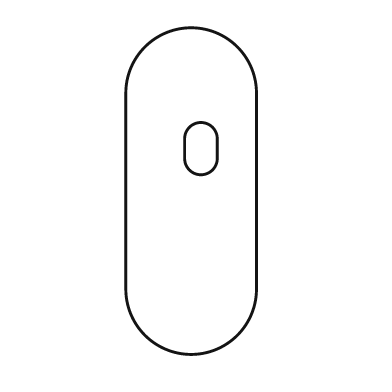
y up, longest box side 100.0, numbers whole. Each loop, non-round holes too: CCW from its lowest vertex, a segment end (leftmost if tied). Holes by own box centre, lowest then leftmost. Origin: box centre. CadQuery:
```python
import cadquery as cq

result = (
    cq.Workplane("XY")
    .moveTo(-20.0, -30.0)
    .threePointArc((0.0, -50.0), (20.0, -30.0))
    .lineTo(20.0, 30.0)
    .threePointArc((0.0, 50.0), (-20.0, 30.0))
    .close()
    .moveTo(-2.0, 10.0)
    .threePointArc((3.0, 5.0), (8.0, 10.0))
    .lineTo(8.0, 16.0)
    .threePointArc((3.0, 21.0), (-2.0, 16.0))
    .close()
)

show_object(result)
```